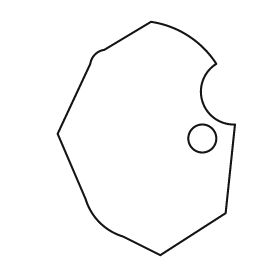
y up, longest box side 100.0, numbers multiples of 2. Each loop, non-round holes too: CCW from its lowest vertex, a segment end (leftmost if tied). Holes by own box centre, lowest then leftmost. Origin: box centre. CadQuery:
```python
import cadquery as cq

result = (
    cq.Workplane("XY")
    .moveTo(6.0, -50.0)
    .lineTo(34.0, -32.0)
    .lineTo(38.0, 6.0)
    .threePointArc((24.0, 16.0), (30.0, 32.0))
    .threePointArc((18.0, 44.0), (2.0, 50.0))
    .lineTo(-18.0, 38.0)
    .threePointArc((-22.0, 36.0), (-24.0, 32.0))
    .lineTo(-38.0, 2.0)
    .lineTo(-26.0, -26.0)
    .threePointArc((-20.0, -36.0), (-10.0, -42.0))
    .close()
    .moveTo(24.0, 0.0)
    .circle(6.0)
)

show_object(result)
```